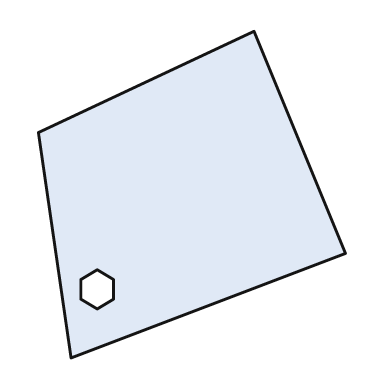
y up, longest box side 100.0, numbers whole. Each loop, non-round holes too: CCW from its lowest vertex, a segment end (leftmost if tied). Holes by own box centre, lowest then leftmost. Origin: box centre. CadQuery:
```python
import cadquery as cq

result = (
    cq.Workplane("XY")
    .moveTo(-37.0, -50.0)
    .lineTo(47.0, -18.0)
    .lineTo(19.0, 50.0)
    .lineTo(-47.0, 19.0)
    .close()
    .moveTo(-29.0, -35.0)
    .lineTo(-24.0, -32.0)
    .lineTo(-24.0, -26.0)
    .lineTo(-29.0, -23.0)
    .lineTo(-34.0, -26.0)
    .lineTo(-34.0, -32.0)
    .close()
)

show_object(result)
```